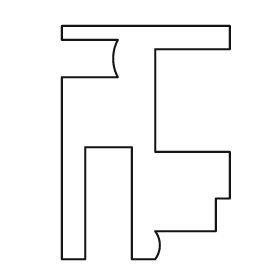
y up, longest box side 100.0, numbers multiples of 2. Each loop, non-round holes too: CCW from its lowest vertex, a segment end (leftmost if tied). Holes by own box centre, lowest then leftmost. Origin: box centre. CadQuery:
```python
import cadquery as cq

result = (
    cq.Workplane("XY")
    .moveTo(-36.0, -50.0)
    .lineTo(-26.0, -50.0)
    .lineTo(-26.0, -2.0)
    .lineTo(-6.0, -2.0)
    .lineTo(-6.0, -50.0)
    .lineTo(4.0, -50.0)
    .threePointArc((6.0, -44.0), (4.0, -38.0))
    .lineTo(30.0, -38.0)
    .lineTo(30.0, -24.0)
    .lineTo(36.0, -24.0)
    .lineTo(36.0, -4.0)
    .lineTo(4.0, -4.0)
    .lineTo(4.0, 40.0)
    .lineTo(36.0, 40.0)
    .lineTo(36.0, 50.0)
    .lineTo(-36.0, 50.0)
    .lineTo(-36.0, 44.0)
    .lineTo(-12.0, 44.0)
    .threePointArc((-14.0, 36.0), (-12.0, 28.0))
    .lineTo(-36.0, 28.0)
    .close()
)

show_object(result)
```